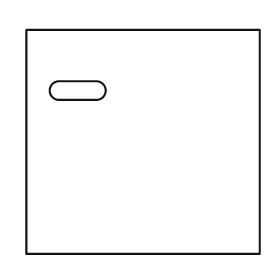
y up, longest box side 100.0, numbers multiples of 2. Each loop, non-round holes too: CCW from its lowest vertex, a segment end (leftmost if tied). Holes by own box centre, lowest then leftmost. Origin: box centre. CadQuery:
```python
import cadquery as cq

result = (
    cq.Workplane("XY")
    .moveTo(-50.0, -48.0)
    .lineTo(50.0, -48.0)
    .lineTo(50.0, 48.0)
    .lineTo(-50.0, 48.0)
    .close()
    .moveTo(-36.0, 18.0)
    .lineTo(-20.0, 18.0)
    .threePointArc((-16.0, 22.0), (-20.0, 26.0))
    .lineTo(-36.0, 26.0)
    .threePointArc((-40.0, 22.0), (-36.0, 18.0))
    .close()
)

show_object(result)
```